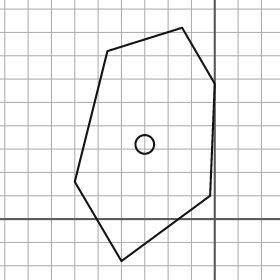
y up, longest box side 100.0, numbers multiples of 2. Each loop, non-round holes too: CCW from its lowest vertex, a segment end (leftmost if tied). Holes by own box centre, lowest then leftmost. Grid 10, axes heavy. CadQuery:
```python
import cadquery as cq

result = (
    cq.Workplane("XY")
    .moveTo(-40.0, -18.0)
    .lineTo(-2.0, 10.0)
    .lineTo(0.0, 58.0)
    .lineTo(-14.0, 82.0)
    .lineTo(-46.0, 72.0)
    .lineTo(-60.0, 16.0)
    .close()
    .moveTo(-30.0, 32.0)
    .circle(4.0)
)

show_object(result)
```